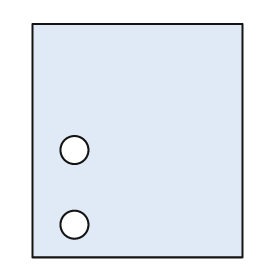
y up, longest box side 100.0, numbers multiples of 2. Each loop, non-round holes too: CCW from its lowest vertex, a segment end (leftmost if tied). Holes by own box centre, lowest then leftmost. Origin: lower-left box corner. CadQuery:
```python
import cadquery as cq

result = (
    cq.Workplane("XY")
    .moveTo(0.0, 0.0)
    .lineTo(90.0, 0.0)
    .lineTo(90.0, 100.0)
    .lineTo(0.0, 100.0)
    .close()
    .moveTo(18.0, 14.0)
    .circle(6.0)
    .moveTo(18.0, 46.0)
    .circle(6.0)
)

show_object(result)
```